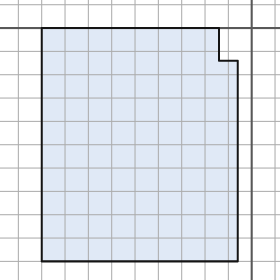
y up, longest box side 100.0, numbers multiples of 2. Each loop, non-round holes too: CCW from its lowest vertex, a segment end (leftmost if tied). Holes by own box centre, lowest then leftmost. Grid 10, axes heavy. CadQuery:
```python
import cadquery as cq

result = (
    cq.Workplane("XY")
    .moveTo(-90.0, -100.0)
    .lineTo(-6.0, -100.0)
    .lineTo(-6.0, -14.0)
    .lineTo(-14.0, -14.0)
    .lineTo(-14.0, 0.0)
    .lineTo(-90.0, 0.0)
    .close()
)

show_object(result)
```